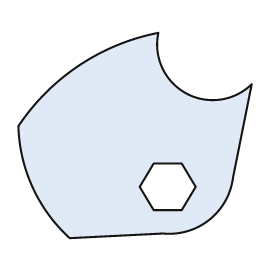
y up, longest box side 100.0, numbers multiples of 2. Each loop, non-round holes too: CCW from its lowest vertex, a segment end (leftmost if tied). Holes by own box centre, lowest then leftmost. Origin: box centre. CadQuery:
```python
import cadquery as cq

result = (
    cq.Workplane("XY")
    .moveTo(-28.0, -44.0)
    .lineTo(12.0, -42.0)
    .threePointArc((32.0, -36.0), (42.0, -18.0))
    .lineTo(50.0, 22.0)
    .threePointArc((22.0, 18.0), (10.0, 44.0))
    .threePointArc((-24.0, 30.0), (-50.0, 4.0))
    .threePointArc((-44.0, -22.0), (-28.0, -44.0))
    .close()
    .moveTo(8.0, -32.0)
    .lineTo(20.0, -32.0)
    .lineTo(26.0, -22.0)
    .lineTo(20.0, -12.0)
    .lineTo(8.0, -12.0)
    .lineTo(2.0, -22.0)
    .close()
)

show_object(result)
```